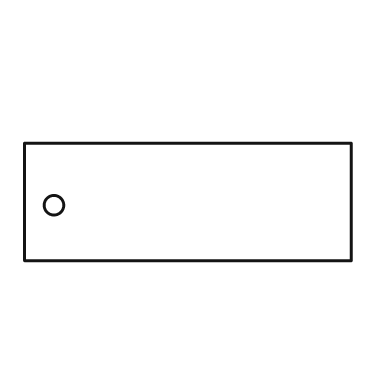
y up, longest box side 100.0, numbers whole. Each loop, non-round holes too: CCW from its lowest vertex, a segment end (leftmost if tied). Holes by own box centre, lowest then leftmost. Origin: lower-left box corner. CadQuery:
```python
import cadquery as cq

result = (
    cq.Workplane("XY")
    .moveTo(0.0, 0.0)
    .lineTo(100.0, 0.0)
    .lineTo(100.0, 36.0)
    .lineTo(0.0, 36.0)
    .close()
    .moveTo(9.0, 17.0)
    .circle(3.0)
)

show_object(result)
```